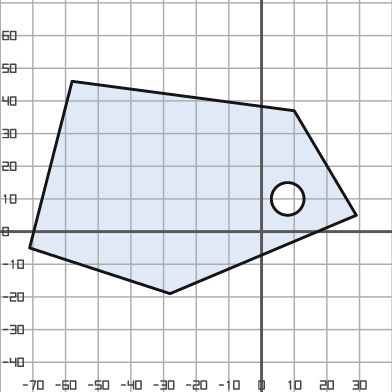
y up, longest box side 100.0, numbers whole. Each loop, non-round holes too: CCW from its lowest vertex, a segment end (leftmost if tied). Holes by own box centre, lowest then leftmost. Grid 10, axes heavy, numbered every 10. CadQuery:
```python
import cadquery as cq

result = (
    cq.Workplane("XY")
    .moveTo(-28.0, -19.0)
    .lineTo(29.0, 5.0)
    .lineTo(10.0, 37.0)
    .lineTo(-58.0, 46.0)
    .lineTo(-71.0, -5.0)
    .close()
    .moveTo(8.0, 10.0)
    .circle(5.0)
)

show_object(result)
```